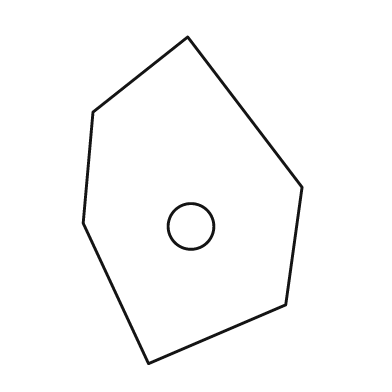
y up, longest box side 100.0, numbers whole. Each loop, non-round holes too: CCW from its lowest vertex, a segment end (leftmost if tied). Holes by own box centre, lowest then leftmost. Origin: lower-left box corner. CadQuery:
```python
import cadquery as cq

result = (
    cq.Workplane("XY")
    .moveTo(20.0, 0.0)
    .lineTo(62.0, 18.0)
    .lineTo(67.0, 54.0)
    .lineTo(32.0, 100.0)
    .lineTo(3.0, 77.0)
    .lineTo(0.0, 43.0)
    .close()
    .moveTo(33.0, 42.0)
    .circle(7.0)
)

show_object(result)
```